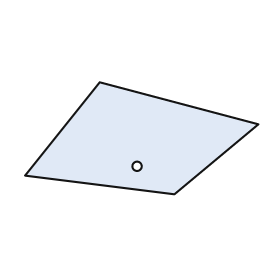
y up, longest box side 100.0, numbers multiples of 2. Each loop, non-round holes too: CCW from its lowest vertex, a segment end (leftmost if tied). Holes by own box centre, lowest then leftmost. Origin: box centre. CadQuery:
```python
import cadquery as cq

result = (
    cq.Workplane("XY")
    .moveTo(14.0, -24.0)
    .lineTo(50.0, 6.0)
    .lineTo(-18.0, 24.0)
    .lineTo(-50.0, -16.0)
    .close()
    .moveTo(-2.0, -12.0)
    .circle(2.0)
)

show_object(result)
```